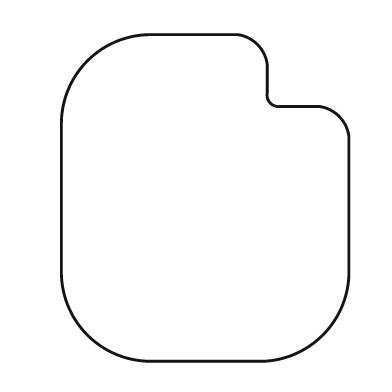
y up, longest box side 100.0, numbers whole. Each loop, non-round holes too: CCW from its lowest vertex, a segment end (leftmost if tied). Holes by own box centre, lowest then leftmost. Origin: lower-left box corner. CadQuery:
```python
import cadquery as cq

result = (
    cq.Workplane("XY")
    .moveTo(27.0, 0.0)
    .lineTo(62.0, 0.0)
    .threePointArc((80.0, 8.0), (88.0, 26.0))
    .lineTo(88.0, 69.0)
    .threePointArc((85.0, 75.0), (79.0, 78.0))
    .lineTo(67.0, 78.0)
    .threePointArc((64.0, 79.0), (63.0, 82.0))
    .lineTo(63.0, 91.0)
    .threePointArc((60.0, 97.0), (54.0, 100.0))
    .lineTo(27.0, 100.0)
    .threePointArc((8.0, 92.0), (0.0, 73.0))
    .lineTo(0.0, 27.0)
    .threePointArc((8.0, 8.0), (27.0, 0.0))
    .close()
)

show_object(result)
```